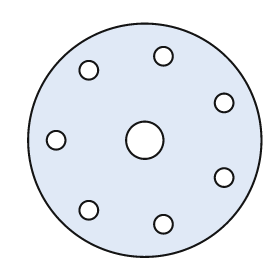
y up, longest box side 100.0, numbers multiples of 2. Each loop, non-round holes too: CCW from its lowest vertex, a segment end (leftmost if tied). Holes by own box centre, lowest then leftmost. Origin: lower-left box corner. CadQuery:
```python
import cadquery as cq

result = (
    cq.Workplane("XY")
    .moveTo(50.0, 50.0)
    .circle(50.0)
    .moveTo(58.0, 14.0)
    .circle(4.0)
    .moveTo(26.0, 20.0)
    .circle(4.0)
    .moveTo(84.0, 34.0)
    .circle(4.0)
    .moveTo(12.0, 50.0)
    .circle(4.0)
    .moveTo(50.0, 50.0)
    .circle(8.0)
    .moveTo(84.0, 66.0)
    .circle(4.0)
    .moveTo(26.0, 80.0)
    .circle(4.0)
    .moveTo(58.0, 86.0)
    .circle(4.0)
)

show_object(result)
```